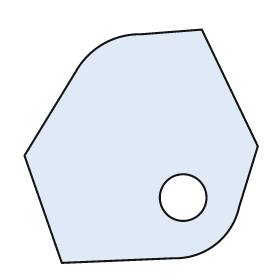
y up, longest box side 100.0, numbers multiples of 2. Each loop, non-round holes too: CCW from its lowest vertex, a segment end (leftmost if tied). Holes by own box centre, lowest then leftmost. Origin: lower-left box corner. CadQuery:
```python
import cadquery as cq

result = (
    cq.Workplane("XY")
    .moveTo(16.0, 0.0)
    .lineTo(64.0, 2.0)
    .threePointArc((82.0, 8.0), (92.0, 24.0))
    .lineTo(100.0, 50.0)
    .lineTo(76.0, 100.0)
    .lineTo(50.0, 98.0)
    .threePointArc((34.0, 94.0), (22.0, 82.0))
    .lineTo(0.0, 46.0)
    .close()
    .moveTo(68.0, 28.0)
    .circle(10.0)
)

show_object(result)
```